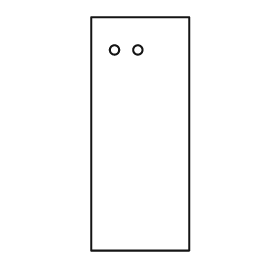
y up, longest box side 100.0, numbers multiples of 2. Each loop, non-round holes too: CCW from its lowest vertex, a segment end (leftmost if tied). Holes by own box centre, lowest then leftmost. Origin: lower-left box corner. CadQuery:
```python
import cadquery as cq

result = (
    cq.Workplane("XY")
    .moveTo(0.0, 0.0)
    .lineTo(42.0, 0.0)
    .lineTo(42.0, 100.0)
    .lineTo(0.0, 100.0)
    .close()
    .moveTo(10.0, 86.0)
    .circle(2.0)
    .moveTo(20.0, 86.0)
    .circle(2.0)
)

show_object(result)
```